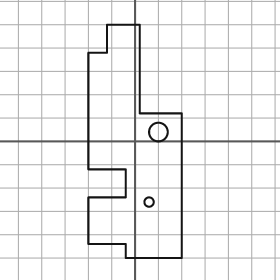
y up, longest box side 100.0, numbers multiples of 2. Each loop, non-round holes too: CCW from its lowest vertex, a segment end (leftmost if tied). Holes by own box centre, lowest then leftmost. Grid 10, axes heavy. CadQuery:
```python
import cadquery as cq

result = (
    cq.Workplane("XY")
    .moveTo(-4.0, -50.0)
    .lineTo(20.0, -50.0)
    .lineTo(20.0, 12.0)
    .lineTo(2.0, 12.0)
    .lineTo(2.0, 50.0)
    .lineTo(-12.0, 50.0)
    .lineTo(-12.0, 38.0)
    .lineTo(-20.0, 38.0)
    .lineTo(-20.0, -12.0)
    .lineTo(-4.0, -12.0)
    .lineTo(-4.0, -24.0)
    .lineTo(-20.0, -24.0)
    .lineTo(-20.0, -44.0)
    .lineTo(-4.0, -44.0)
    .close()
    .moveTo(6.0, -26.0)
    .circle(2.0)
    .moveTo(10.0, 4.0)
    .circle(4.0)
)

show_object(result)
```